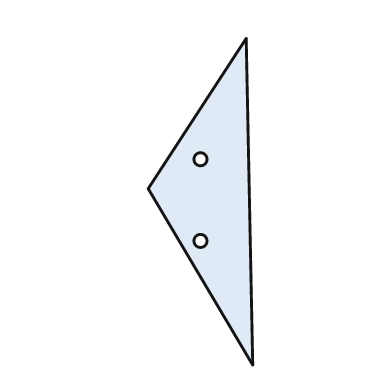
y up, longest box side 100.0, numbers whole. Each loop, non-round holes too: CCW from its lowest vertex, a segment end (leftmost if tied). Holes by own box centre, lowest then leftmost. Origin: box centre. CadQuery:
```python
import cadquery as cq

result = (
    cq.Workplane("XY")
    .moveTo(16.0, -50.0)
    .lineTo(14.0, 50.0)
    .lineTo(-16.0, 4.0)
    .close()
    .moveTo(0.0, -12.0)
    .circle(2.0)
    .moveTo(0.0, 13.0)
    .circle(2.0)
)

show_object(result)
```